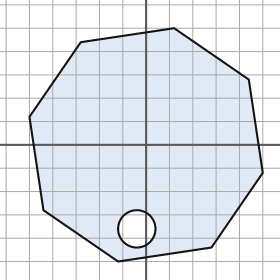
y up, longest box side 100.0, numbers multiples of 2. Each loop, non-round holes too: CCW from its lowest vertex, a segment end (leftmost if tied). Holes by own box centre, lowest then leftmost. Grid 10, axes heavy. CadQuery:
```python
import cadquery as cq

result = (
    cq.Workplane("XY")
    .moveTo(-12.0, -50.0)
    .lineTo(28.0, -44.0)
    .lineTo(50.0, -12.0)
    .lineTo(44.0, 28.0)
    .lineTo(12.0, 50.0)
    .lineTo(-28.0, 44.0)
    .lineTo(-50.0, 12.0)
    .lineTo(-44.0, -28.0)
    .close()
    .moveTo(-4.0, -36.0)
    .circle(8.0)
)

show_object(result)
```